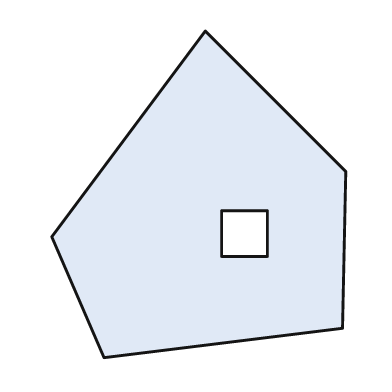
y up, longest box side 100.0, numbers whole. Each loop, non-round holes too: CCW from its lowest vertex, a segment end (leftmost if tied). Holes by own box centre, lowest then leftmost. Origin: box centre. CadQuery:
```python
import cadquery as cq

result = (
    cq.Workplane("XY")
    .moveTo(-29.0, -50.0)
    .lineTo(44.0, -41.0)
    .lineTo(45.0, 7.0)
    .lineTo(2.0, 50.0)
    .lineTo(-45.0, -13.0)
    .close()
    .moveTo(7.0, -19.0)
    .lineTo(21.0, -19.0)
    .lineTo(21.0, -5.0)
    .lineTo(7.0, -5.0)
    .close()
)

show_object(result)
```